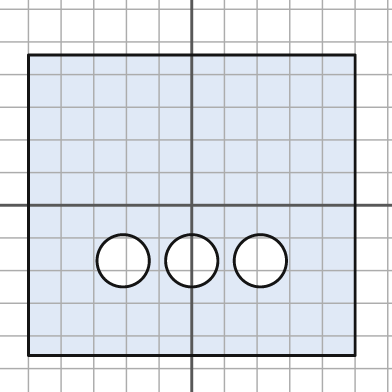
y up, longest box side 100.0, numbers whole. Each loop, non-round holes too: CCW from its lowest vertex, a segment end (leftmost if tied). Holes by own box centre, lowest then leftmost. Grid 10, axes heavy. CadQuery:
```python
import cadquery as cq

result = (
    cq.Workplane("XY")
    .moveTo(-50.0, -46.0)
    .lineTo(50.0, -46.0)
    .lineTo(50.0, 46.0)
    .lineTo(-50.0, 46.0)
    .close()
    .moveTo(-21.0, -17.0)
    .circle(8.0)
    .moveTo(0.0, -17.0)
    .circle(8.0)
    .moveTo(21.0, -17.0)
    .circle(8.0)
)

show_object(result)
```